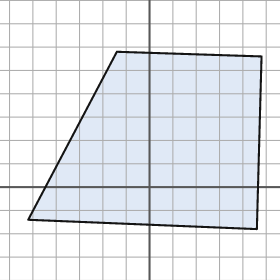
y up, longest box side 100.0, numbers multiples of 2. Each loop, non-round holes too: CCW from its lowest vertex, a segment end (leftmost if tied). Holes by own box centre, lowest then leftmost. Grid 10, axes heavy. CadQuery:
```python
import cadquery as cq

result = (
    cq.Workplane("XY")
    .moveTo(46.0, -18.0)
    .lineTo(48.0, 56.0)
    .lineTo(-14.0, 58.0)
    .lineTo(-52.0, -14.0)
    .close()
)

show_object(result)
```